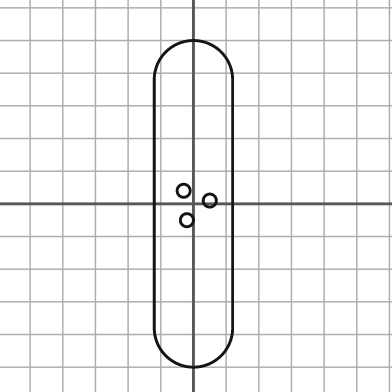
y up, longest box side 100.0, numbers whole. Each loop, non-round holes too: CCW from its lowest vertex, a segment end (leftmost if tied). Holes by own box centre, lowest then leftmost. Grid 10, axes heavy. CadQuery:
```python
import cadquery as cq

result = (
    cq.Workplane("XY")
    .moveTo(-12.0, -38.0)
    .threePointArc((0.0, -50.0), (12.0, -38.0))
    .lineTo(12.0, 38.0)
    .threePointArc((0.0, 50.0), (-12.0, 38.0))
    .close()
    .moveTo(-2.0, -5.0)
    .circle(2.0)
    .moveTo(5.0, 1.0)
    .circle(2.0)
    .moveTo(-3.0, 4.0)
    .circle(2.0)
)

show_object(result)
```